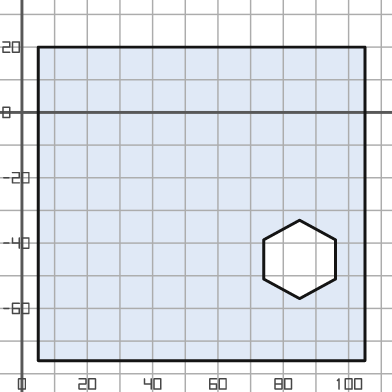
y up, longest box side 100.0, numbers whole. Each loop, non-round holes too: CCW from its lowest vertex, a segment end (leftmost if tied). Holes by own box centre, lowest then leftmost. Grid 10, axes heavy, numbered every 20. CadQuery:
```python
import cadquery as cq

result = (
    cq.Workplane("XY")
    .moveTo(5.0, -76.0)
    .lineTo(105.0, -76.0)
    .lineTo(105.0, 20.0)
    .lineTo(5.0, 20.0)
    .close()
    .moveTo(85.0, -57.0)
    .lineTo(96.0, -51.0)
    .lineTo(96.0, -39.0)
    .lineTo(85.0, -33.0)
    .lineTo(74.0, -39.0)
    .lineTo(74.0, -51.0)
    .close()
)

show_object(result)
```